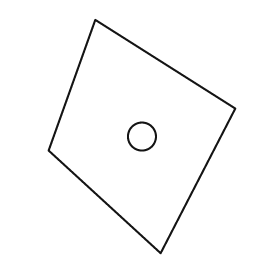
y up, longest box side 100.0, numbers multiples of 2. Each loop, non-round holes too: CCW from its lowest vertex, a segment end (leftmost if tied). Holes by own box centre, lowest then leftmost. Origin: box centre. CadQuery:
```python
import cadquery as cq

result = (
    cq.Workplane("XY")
    .moveTo(8.0, -50.0)
    .lineTo(40.0, 12.0)
    .lineTo(-20.0, 50.0)
    .lineTo(-40.0, -6.0)
    .close()
    .moveTo(0.0, 0.0)
    .circle(6.0)
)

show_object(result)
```